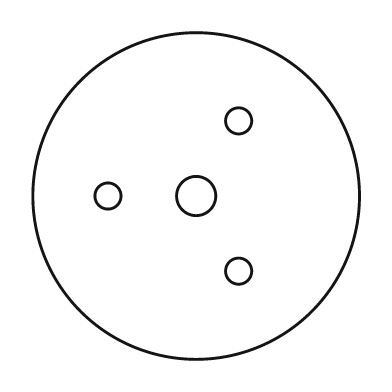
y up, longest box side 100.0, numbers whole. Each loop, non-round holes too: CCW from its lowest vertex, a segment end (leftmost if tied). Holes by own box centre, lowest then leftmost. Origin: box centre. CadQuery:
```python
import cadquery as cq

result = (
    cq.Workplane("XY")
    .moveTo(0.0, 0.0)
    .circle(50.0)
    .moveTo(13.0, -23.0)
    .circle(4.0)
    .moveTo(-27.0, 0.0)
    .circle(4.0)
    .moveTo(0.0, 0.0)
    .circle(6.0)
    .moveTo(13.0, 23.0)
    .circle(4.0)
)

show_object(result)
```